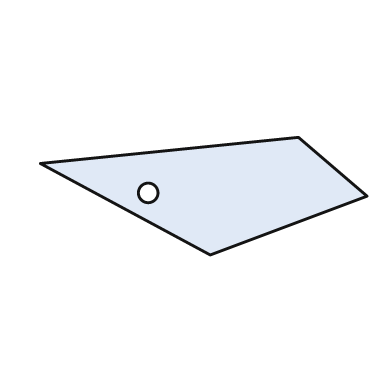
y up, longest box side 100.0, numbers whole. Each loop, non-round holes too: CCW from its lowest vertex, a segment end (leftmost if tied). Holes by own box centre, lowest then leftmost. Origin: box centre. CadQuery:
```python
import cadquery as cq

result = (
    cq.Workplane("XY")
    .moveTo(2.0, -18.0)
    .lineTo(50.0, 0.0)
    .lineTo(29.0, 18.0)
    .lineTo(-50.0, 10.0)
    .close()
    .moveTo(-17.0, 1.0)
    .circle(3.0)
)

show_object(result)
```